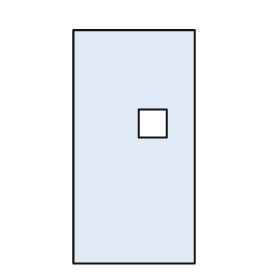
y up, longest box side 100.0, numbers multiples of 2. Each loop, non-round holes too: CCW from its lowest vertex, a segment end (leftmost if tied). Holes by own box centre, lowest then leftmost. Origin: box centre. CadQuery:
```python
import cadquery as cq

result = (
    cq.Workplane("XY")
    .moveTo(-26.0, -50.0)
    .lineTo(26.0, -50.0)
    .lineTo(26.0, 50.0)
    .lineTo(-26.0, 50.0)
    .close()
    .moveTo(2.0, 4.0)
    .lineTo(14.0, 4.0)
    .lineTo(14.0, 16.0)
    .lineTo(2.0, 16.0)
    .close()
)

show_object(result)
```